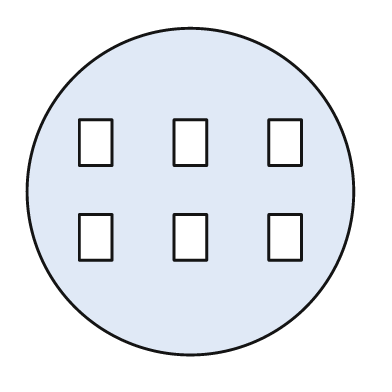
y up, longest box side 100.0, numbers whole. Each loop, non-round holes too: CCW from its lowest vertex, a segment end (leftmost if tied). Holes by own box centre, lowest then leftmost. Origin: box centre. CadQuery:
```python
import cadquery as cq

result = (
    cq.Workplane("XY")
    .moveTo(0.0, 0.0)
    .circle(50.0)
    .moveTo(-34.0, -21.0)
    .lineTo(-24.0, -21.0)
    .lineTo(-24.0, -7.0)
    .lineTo(-34.0, -7.0)
    .close()
    .moveTo(-5.0, -21.0)
    .lineTo(5.0, -21.0)
    .lineTo(5.0, -7.0)
    .lineTo(-5.0, -7.0)
    .close()
    .moveTo(24.0, -21.0)
    .lineTo(34.0, -21.0)
    .lineTo(34.0, -7.0)
    .lineTo(24.0, -7.0)
    .close()
    .moveTo(-34.0, 8.0)
    .lineTo(-24.0, 8.0)
    .lineTo(-24.0, 22.0)
    .lineTo(-34.0, 22.0)
    .close()
    .moveTo(-5.0, 8.0)
    .lineTo(5.0, 8.0)
    .lineTo(5.0, 22.0)
    .lineTo(-5.0, 22.0)
    .close()
    .moveTo(24.0, 8.0)
    .lineTo(34.0, 8.0)
    .lineTo(34.0, 22.0)
    .lineTo(24.0, 22.0)
    .close()
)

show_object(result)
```